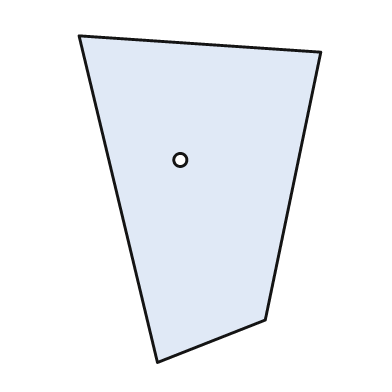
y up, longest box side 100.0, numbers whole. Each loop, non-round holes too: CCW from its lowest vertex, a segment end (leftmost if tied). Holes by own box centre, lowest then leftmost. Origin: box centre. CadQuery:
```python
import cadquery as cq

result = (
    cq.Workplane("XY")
    .moveTo(-13.0, -50.0)
    .lineTo(20.0, -37.0)
    .lineTo(37.0, 45.0)
    .lineTo(-37.0, 50.0)
    .close()
    .moveTo(-6.0, 12.0)
    .circle(2.0)
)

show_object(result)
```